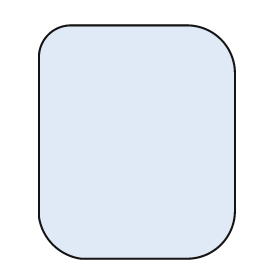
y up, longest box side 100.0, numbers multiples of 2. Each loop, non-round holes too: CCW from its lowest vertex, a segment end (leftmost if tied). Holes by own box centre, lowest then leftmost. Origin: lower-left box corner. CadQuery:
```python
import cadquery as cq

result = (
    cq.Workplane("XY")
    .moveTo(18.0, 0.0)
    .lineTo(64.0, 0.0)
    .threePointArc((78.0, 6.0), (84.0, 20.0))
    .lineTo(84.0, 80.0)
    .threePointArc((78.0, 94.0), (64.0, 100.0))
    .lineTo(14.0, 100.0)
    .threePointArc((4.0, 96.0), (0.0, 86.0))
    .lineTo(0.0, 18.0)
    .threePointArc((6.0, 6.0), (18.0, 0.0))
    .close()
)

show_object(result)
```